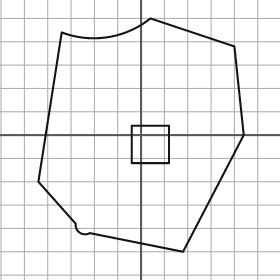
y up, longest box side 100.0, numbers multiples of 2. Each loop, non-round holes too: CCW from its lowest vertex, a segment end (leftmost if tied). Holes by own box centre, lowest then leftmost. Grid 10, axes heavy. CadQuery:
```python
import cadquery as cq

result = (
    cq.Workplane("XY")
    .moveTo(18.0, -50.0)
    .lineTo(44.0, 0.0)
    .lineTo(40.0, 38.0)
    .lineTo(4.0, 50.0)
    .threePointArc((-14.0, 42.0), (-34.0, 44.0))
    .lineTo(-44.0, -20.0)
    .lineTo(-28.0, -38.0)
    .threePointArc((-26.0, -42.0), (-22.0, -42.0))
    .close()
    .moveTo(-4.0, -12.0)
    .lineTo(12.0, -12.0)
    .lineTo(12.0, 4.0)
    .lineTo(-4.0, 4.0)
    .close()
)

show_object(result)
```